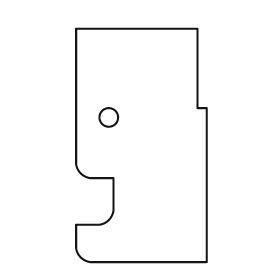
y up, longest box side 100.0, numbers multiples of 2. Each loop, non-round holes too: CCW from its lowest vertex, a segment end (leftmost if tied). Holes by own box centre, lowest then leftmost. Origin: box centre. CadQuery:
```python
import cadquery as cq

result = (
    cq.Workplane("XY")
    .moveTo(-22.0, -50.0)
    .lineTo(28.0, -50.0)
    .lineTo(28.0, 16.0)
    .lineTo(24.0, 16.0)
    .lineTo(24.0, 50.0)
    .lineTo(-28.0, 50.0)
    .lineTo(-28.0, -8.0)
    .threePointArc((-26.0, -12.0), (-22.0, -14.0))
    .lineTo(-12.0, -14.0)
    .lineTo(-12.0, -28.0)
    .threePointArc((-14.0, -32.0), (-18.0, -34.0))
    .lineTo(-28.0, -34.0)
    .lineTo(-28.0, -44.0)
    .threePointArc((-26.0, -48.0), (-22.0, -50.0))
    .close()
    .moveTo(-14.0, 12.0)
    .circle(4.0)
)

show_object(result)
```